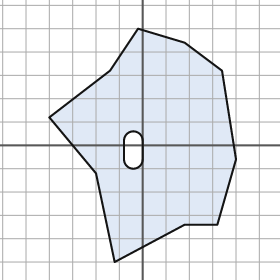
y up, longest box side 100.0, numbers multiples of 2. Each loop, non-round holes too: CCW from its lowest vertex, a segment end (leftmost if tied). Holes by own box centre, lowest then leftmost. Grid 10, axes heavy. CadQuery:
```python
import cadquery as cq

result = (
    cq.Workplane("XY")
    .moveTo(-12.0, -50.0)
    .lineTo(18.0, -34.0)
    .lineTo(32.0, -34.0)
    .lineTo(40.0, -6.0)
    .lineTo(34.0, 32.0)
    .lineTo(18.0, 44.0)
    .lineTo(-2.0, 50.0)
    .lineTo(-14.0, 32.0)
    .lineTo(-40.0, 12.0)
    .lineTo(-20.0, -12.0)
    .close()
    .moveTo(-8.0, -6.0)
    .threePointArc((-4.0, -10.0), (0.0, -6.0))
    .lineTo(0.0, 2.0)
    .threePointArc((-4.0, 6.0), (-8.0, 2.0))
    .close()
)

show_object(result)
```